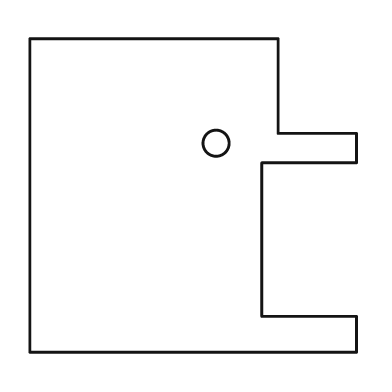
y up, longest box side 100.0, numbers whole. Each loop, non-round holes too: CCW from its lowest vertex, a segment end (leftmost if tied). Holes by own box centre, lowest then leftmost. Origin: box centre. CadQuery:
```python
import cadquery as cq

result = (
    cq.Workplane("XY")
    .moveTo(-50.0, -48.0)
    .lineTo(50.0, -48.0)
    .lineTo(50.0, -37.0)
    .lineTo(21.0, -37.0)
    .lineTo(21.0, 10.0)
    .lineTo(50.0, 10.0)
    .lineTo(50.0, 19.0)
    .lineTo(26.0, 19.0)
    .lineTo(26.0, 48.0)
    .lineTo(-50.0, 48.0)
    .close()
    .moveTo(7.0, 16.0)
    .circle(4.0)
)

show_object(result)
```